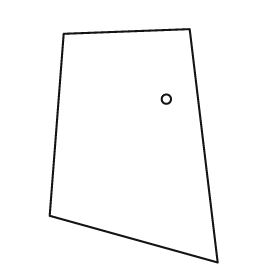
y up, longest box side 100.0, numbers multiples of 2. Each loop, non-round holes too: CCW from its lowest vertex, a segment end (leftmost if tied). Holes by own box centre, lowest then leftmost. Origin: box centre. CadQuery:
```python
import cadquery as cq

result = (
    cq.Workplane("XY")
    .moveTo(36.0, -50.0)
    .lineTo(24.0, 50.0)
    .lineTo(-30.0, 48.0)
    .lineTo(-36.0, -30.0)
    .close()
    .moveTo(14.0, 20.0)
    .circle(2.0)
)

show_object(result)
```